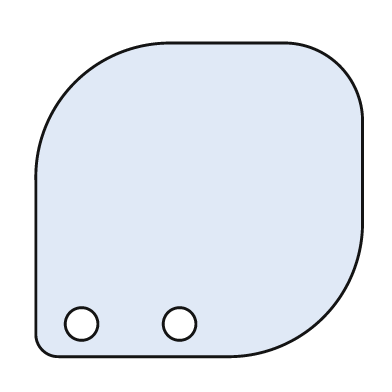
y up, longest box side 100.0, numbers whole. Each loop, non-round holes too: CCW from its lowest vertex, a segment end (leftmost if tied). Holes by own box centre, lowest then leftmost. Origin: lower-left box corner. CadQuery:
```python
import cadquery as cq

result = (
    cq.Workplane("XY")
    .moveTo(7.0, 0.0)
    .lineTo(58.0, 0.0)
    .threePointArc((88.0, 12.0), (100.0, 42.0))
    .lineTo(100.0, 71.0)
    .threePointArc((93.0, 89.0), (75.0, 96.0))
    .lineTo(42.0, 96.0)
    .threePointArc((12.0, 84.0), (0.0, 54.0))
    .lineTo(0.0, 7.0)
    .threePointArc((2.0, 2.0), (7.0, 0.0))
    .close()
    .moveTo(14.0, 10.0)
    .circle(5.0)
    .moveTo(44.0, 10.0)
    .circle(5.0)
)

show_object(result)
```